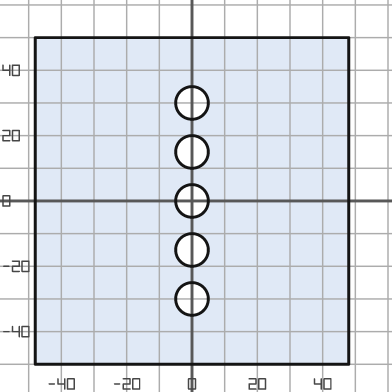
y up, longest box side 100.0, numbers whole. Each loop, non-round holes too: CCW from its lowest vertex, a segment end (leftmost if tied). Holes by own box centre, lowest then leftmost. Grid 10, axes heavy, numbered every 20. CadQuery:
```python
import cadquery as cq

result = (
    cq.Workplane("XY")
    .moveTo(-48.0, -50.0)
    .lineTo(48.0, -50.0)
    .lineTo(48.0, 50.0)
    .lineTo(-48.0, 50.0)
    .close()
    .moveTo(0.0, -30.0)
    .circle(5.0)
    .moveTo(0.0, -15.0)
    .circle(5.0)
    .moveTo(0.0, 0.0)
    .circle(5.0)
    .moveTo(0.0, 15.0)
    .circle(5.0)
    .moveTo(0.0, 30.0)
    .circle(5.0)
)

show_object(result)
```